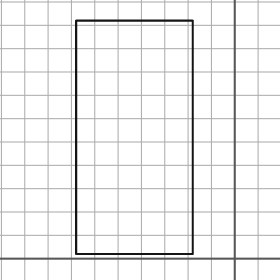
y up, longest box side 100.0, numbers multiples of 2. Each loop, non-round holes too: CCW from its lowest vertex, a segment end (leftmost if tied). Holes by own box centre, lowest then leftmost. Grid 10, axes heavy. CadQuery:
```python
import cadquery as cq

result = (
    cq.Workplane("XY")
    .moveTo(-68.0, 2.0)
    .lineTo(-18.0, 2.0)
    .lineTo(-18.0, 102.0)
    .lineTo(-68.0, 102.0)
    .close()
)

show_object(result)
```